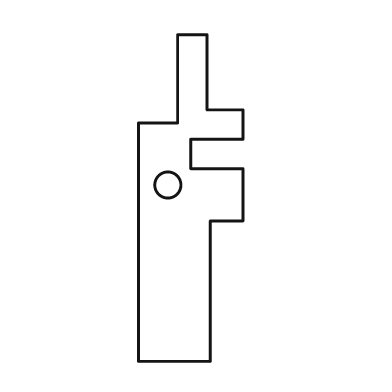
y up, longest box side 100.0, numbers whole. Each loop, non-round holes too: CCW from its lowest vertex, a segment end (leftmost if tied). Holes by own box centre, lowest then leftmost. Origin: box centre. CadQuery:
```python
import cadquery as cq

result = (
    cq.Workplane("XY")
    .moveTo(-16.0, -50.0)
    .lineTo(6.0, -50.0)
    .lineTo(6.0, -7.0)
    .lineTo(16.0, -7.0)
    .lineTo(16.0, 9.0)
    .lineTo(0.0, 9.0)
    .lineTo(0.0, 18.0)
    .lineTo(16.0, 18.0)
    .lineTo(16.0, 27.0)
    .lineTo(5.0, 27.0)
    .lineTo(5.0, 50.0)
    .lineTo(-4.0, 50.0)
    .lineTo(-4.0, 23.0)
    .lineTo(-16.0, 23.0)
    .close()
    .moveTo(-7.0, 4.0)
    .circle(4.0)
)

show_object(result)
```